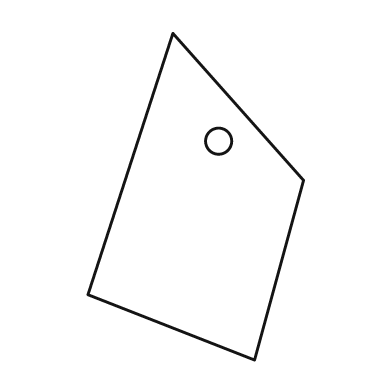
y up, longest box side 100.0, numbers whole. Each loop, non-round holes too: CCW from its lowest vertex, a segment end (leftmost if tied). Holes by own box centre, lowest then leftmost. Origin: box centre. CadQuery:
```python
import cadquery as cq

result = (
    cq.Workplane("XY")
    .moveTo(18.0, -50.0)
    .lineTo(33.0, 5.0)
    .lineTo(-7.0, 50.0)
    .lineTo(-33.0, -30.0)
    .close()
    .moveTo(7.0, 17.0)
    .circle(4.0)
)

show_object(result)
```